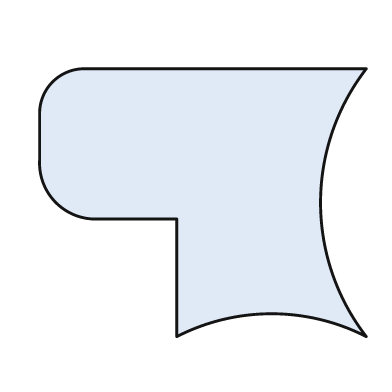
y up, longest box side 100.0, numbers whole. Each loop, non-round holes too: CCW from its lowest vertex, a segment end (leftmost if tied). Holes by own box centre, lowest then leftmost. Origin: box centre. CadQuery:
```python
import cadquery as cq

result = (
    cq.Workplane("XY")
    .moveTo(-8.0, -41.0)
    .threePointArc((21.0, -34.0), (50.0, -41.0))
    .threePointArc((36.0, 0.0), (50.0, 41.0))
    .lineTo(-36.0, 41.0)
    .threePointArc((-46.0, 37.0), (-50.0, 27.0))
    .lineTo(-50.0, 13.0)
    .threePointArc((-45.0, 0.0), (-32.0, -5.0))
    .lineTo(-8.0, -5.0)
    .close()
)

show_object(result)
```